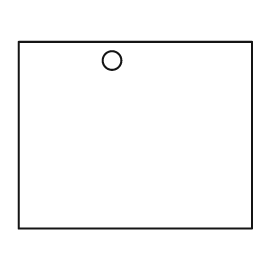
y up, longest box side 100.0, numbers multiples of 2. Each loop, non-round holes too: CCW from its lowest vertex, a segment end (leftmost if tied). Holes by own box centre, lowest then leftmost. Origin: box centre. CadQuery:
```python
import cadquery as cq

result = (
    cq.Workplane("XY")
    .moveTo(-50.0, -40.0)
    .lineTo(50.0, -40.0)
    .lineTo(50.0, 40.0)
    .lineTo(-50.0, 40.0)
    .close()
    .moveTo(-10.0, 32.0)
    .circle(4.0)
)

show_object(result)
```